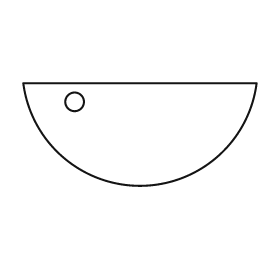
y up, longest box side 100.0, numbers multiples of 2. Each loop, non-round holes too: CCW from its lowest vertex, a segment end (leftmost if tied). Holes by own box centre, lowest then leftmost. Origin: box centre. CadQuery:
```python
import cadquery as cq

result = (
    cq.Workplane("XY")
    .moveTo(-50.0, 22.0)
    .threePointArc((0.0, -22.0), (50.0, 22.0))
    .close()
    .moveTo(-28.0, 14.0)
    .circle(4.0)
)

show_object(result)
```